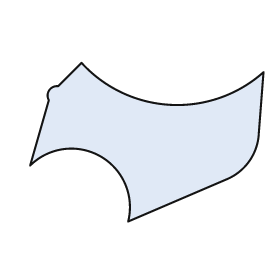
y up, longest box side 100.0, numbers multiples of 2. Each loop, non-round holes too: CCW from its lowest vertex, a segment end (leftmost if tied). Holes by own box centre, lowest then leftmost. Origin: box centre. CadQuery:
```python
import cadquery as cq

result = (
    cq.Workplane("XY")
    .moveTo(-8.0, -34.0)
    .lineTo(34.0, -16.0)
    .threePointArc((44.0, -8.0), (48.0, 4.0))
    .lineTo(50.0, 30.0)
    .threePointArc((10.0, 16.0), (-28.0, 34.0))
    .lineTo(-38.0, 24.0)
    .threePointArc((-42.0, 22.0), (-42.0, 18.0))
    .lineTo(-50.0, -10.0)
    .threePointArc((-20.0, -6.0), (-8.0, -34.0))
    .close()
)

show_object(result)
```